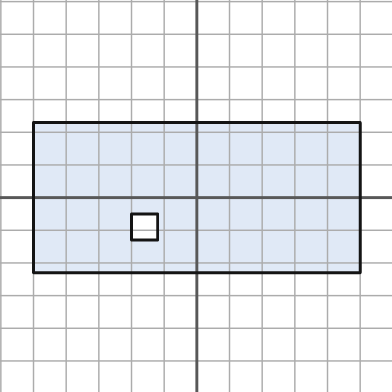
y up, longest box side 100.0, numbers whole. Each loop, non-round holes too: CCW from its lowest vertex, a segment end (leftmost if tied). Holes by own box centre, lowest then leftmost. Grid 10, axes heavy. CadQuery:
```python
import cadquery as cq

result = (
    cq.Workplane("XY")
    .moveTo(-50.0, -23.0)
    .lineTo(50.0, -23.0)
    .lineTo(50.0, 23.0)
    .lineTo(-50.0, 23.0)
    .close()
    .moveTo(-20.0, -13.0)
    .lineTo(-12.0, -13.0)
    .lineTo(-12.0, -5.0)
    .lineTo(-20.0, -5.0)
    .close()
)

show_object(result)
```